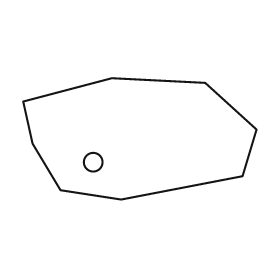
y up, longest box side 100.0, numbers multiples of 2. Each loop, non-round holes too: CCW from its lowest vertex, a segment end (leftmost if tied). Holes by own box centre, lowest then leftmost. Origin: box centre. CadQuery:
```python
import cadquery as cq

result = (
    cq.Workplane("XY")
    .moveTo(-8.0, -26.0)
    .lineTo(44.0, -16.0)
    .lineTo(50.0, 4.0)
    .lineTo(28.0, 24.0)
    .lineTo(-12.0, 26.0)
    .lineTo(-50.0, 16.0)
    .lineTo(-46.0, -2.0)
    .lineTo(-34.0, -22.0)
    .close()
    .moveTo(-20.0, -10.0)
    .circle(4.0)
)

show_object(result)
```